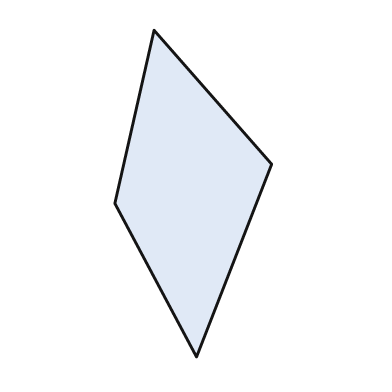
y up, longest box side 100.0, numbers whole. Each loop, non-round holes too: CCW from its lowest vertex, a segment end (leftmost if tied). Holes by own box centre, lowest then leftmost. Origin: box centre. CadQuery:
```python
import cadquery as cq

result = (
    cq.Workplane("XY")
    .moveTo(1.0, -50.0)
    .lineTo(24.0, 9.0)
    .lineTo(-12.0, 50.0)
    .lineTo(-24.0, -3.0)
    .close()
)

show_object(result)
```